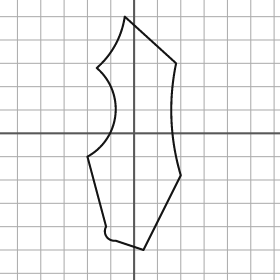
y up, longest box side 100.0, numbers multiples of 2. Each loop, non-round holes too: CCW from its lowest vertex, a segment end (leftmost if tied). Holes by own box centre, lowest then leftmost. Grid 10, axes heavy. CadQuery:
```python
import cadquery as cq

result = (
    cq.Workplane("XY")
    .moveTo(4.0, -50.0)
    .lineTo(20.0, -18.0)
    .threePointArc((16.0, 6.0), (18.0, 30.0))
    .lineTo(-4.0, 50.0)
    .threePointArc((-8.0, 38.0), (-16.0, 28.0))
    .threePointArc((-8.0, 8.0), (-20.0, -10.0))
    .lineTo(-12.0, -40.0)
    .threePointArc((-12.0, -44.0), (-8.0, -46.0))
    .close()
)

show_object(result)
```